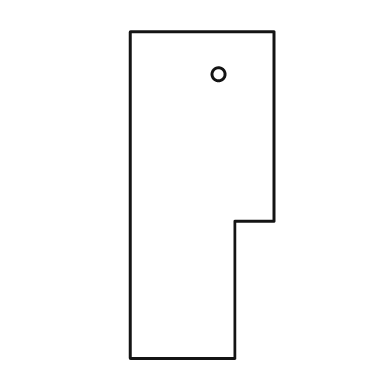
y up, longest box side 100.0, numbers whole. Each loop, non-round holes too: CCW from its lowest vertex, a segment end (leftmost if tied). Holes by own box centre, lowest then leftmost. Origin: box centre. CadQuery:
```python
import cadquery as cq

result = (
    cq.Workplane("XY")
    .moveTo(-22.0, -50.0)
    .lineTo(10.0, -50.0)
    .lineTo(10.0, -8.0)
    .lineTo(22.0, -8.0)
    .lineTo(22.0, 50.0)
    .lineTo(-22.0, 50.0)
    .close()
    .moveTo(5.0, 37.0)
    .circle(2.0)
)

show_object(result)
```